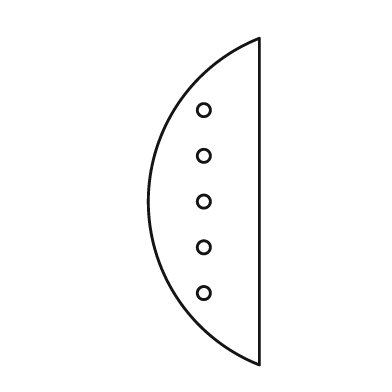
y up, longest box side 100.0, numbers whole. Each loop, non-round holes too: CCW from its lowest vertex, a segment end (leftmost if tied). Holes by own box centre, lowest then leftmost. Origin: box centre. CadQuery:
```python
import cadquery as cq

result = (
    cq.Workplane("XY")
    .moveTo(17.0, -50.0)
    .lineTo(17.0, 50.0)
    .threePointArc((-17.0, 0.0), (17.0, -50.0))
    .close()
    .moveTo(0.0, -28.0)
    .circle(2.0)
    .moveTo(0.0, -14.0)
    .circle(2.0)
    .moveTo(0.0, 0.0)
    .circle(2.0)
    .moveTo(0.0, 14.0)
    .circle(2.0)
    .moveTo(0.0, 28.0)
    .circle(2.0)
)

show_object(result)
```